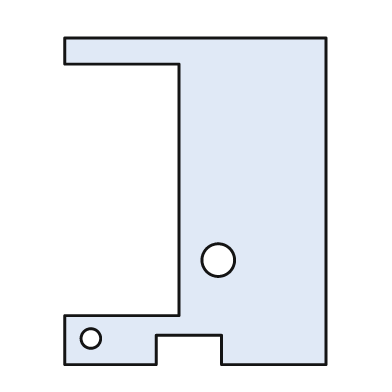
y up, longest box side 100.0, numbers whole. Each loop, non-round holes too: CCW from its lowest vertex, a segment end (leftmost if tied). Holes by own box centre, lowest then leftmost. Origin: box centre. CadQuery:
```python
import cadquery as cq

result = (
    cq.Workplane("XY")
    .moveTo(-40.0, -50.0)
    .lineTo(-12.0, -50.0)
    .lineTo(-12.0, -41.0)
    .lineTo(8.0, -41.0)
    .lineTo(8.0, -50.0)
    .lineTo(40.0, -50.0)
    .lineTo(40.0, 50.0)
    .lineTo(-40.0, 50.0)
    .lineTo(-40.0, 42.0)
    .lineTo(-5.0, 42.0)
    .lineTo(-5.0, -35.0)
    .lineTo(-40.0, -35.0)
    .close()
    .moveTo(-32.0, -42.0)
    .circle(3.0)
    .moveTo(7.0, -18.0)
    .circle(5.0)
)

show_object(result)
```